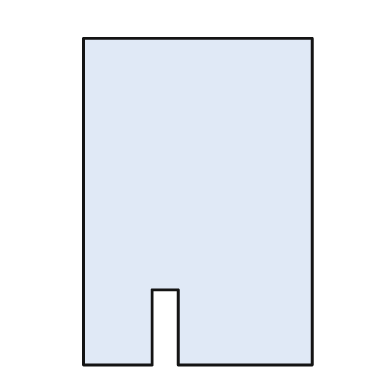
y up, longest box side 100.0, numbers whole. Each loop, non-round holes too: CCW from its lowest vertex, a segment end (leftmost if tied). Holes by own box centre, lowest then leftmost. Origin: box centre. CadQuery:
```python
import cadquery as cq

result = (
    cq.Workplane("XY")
    .moveTo(-35.0, -50.0)
    .lineTo(-14.0, -50.0)
    .lineTo(-14.0, -27.0)
    .lineTo(-6.0, -27.0)
    .lineTo(-6.0, -50.0)
    .lineTo(35.0, -50.0)
    .lineTo(35.0, 50.0)
    .lineTo(-35.0, 50.0)
    .close()
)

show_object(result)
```